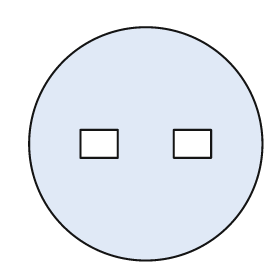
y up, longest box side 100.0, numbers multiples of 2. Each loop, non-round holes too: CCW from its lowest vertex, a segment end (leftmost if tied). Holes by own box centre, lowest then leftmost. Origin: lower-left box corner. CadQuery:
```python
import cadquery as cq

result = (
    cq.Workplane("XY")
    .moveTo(50.0, 50.0)
    .circle(50.0)
    .moveTo(22.0, 44.0)
    .lineTo(38.0, 44.0)
    .lineTo(38.0, 56.0)
    .lineTo(22.0, 56.0)
    .close()
    .moveTo(62.0, 44.0)
    .lineTo(78.0, 44.0)
    .lineTo(78.0, 56.0)
    .lineTo(62.0, 56.0)
    .close()
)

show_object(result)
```